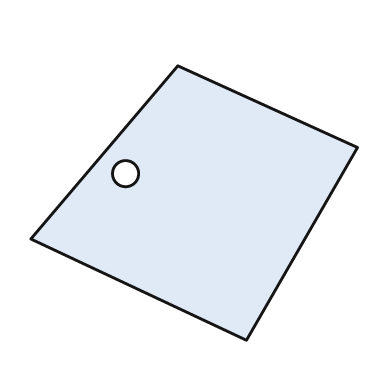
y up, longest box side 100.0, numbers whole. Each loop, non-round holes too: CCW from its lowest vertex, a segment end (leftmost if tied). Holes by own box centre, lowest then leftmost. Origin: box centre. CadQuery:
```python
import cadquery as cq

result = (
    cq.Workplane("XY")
    .moveTo(16.0, -42.0)
    .lineTo(50.0, 17.0)
    .lineTo(-5.0, 42.0)
    .lineTo(-50.0, -11.0)
    .close()
    .moveTo(-21.0, 9.0)
    .circle(4.0)
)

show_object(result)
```